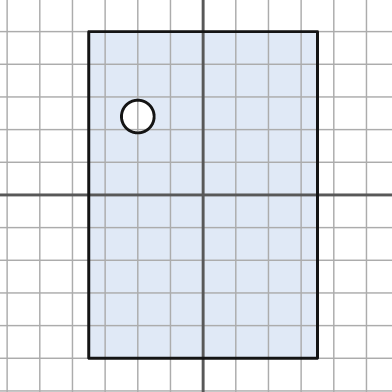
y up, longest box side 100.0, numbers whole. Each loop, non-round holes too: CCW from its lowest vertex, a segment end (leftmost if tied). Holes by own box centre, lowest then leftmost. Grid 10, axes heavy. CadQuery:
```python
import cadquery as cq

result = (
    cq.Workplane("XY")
    .moveTo(-35.0, -50.0)
    .lineTo(35.0, -50.0)
    .lineTo(35.0, 50.0)
    .lineTo(-35.0, 50.0)
    .close()
    .moveTo(-20.0, 24.0)
    .circle(5.0)
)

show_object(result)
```